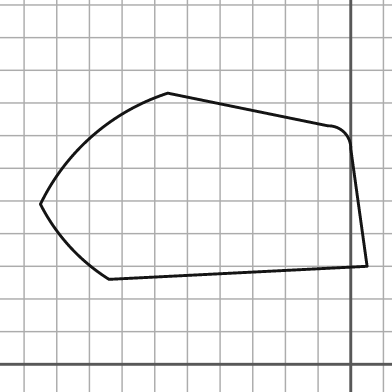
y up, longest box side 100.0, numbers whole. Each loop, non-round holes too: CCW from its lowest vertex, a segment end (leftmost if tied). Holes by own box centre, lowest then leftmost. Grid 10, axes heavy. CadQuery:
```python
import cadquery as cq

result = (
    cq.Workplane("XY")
    .moveTo(-74.0, 26.0)
    .lineTo(5.0, 30.0)
    .lineTo(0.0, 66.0)
    .threePointArc((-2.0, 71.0), (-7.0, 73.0))
    .lineTo(-56.0, 83.0)
    .threePointArc((-79.0, 70.0), (-95.0, 49.0))
    .threePointArc((-86.0, 36.0), (-74.0, 26.0))
    .close()
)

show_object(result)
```